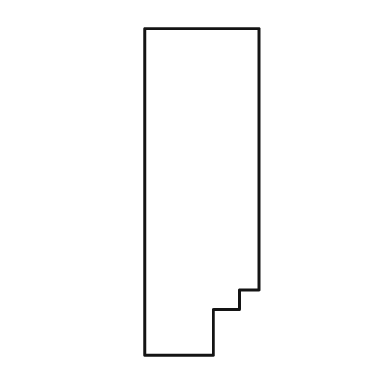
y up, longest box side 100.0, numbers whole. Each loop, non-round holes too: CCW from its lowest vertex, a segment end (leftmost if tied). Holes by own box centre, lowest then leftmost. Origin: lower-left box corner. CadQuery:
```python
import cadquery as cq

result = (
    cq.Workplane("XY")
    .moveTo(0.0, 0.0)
    .lineTo(21.0, 0.0)
    .lineTo(21.0, 14.0)
    .lineTo(29.0, 14.0)
    .lineTo(29.0, 20.0)
    .lineTo(35.0, 20.0)
    .lineTo(35.0, 100.0)
    .lineTo(0.0, 100.0)
    .close()
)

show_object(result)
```